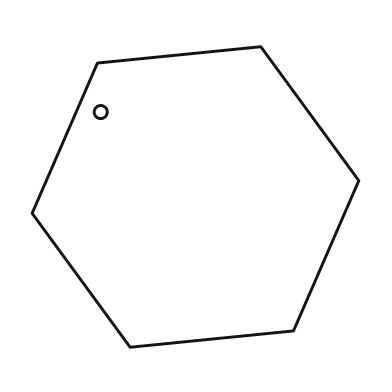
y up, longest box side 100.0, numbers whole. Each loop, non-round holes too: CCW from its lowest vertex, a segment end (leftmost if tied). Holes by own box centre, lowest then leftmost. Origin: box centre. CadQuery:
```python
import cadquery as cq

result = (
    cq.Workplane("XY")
    .moveTo(-20.0, -46.0)
    .lineTo(30.0, -41.0)
    .lineTo(50.0, 5.0)
    .lineTo(20.0, 46.0)
    .lineTo(-30.0, 41.0)
    .lineTo(-50.0, -5.0)
    .close()
    .moveTo(-29.0, 26.0)
    .circle(2.0)
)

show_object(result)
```